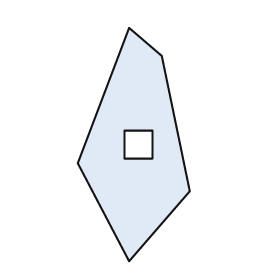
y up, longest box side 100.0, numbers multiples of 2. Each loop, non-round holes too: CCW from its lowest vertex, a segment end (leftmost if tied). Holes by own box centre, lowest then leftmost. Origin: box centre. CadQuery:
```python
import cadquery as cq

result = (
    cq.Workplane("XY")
    .moveTo(-2.0, -50.0)
    .lineTo(24.0, -20.0)
    .lineTo(12.0, 38.0)
    .lineTo(-2.0, 50.0)
    .lineTo(-24.0, -8.0)
    .close()
    .moveTo(-4.0, -6.0)
    .lineTo(8.0, -6.0)
    .lineTo(8.0, 6.0)
    .lineTo(-4.0, 6.0)
    .close()
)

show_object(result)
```